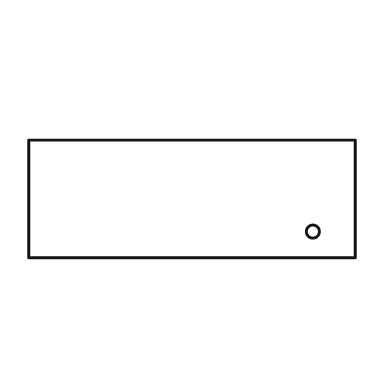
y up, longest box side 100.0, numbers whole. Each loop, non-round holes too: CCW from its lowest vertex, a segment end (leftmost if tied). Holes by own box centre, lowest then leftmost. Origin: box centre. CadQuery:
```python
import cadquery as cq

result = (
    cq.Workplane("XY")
    .moveTo(-50.0, -18.0)
    .lineTo(50.0, -18.0)
    .lineTo(50.0, 18.0)
    .lineTo(-50.0, 18.0)
    .close()
    .moveTo(37.0, -10.0)
    .circle(2.0)
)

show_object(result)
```